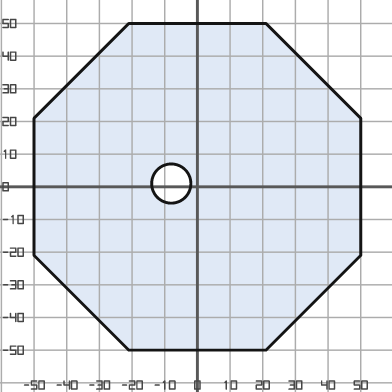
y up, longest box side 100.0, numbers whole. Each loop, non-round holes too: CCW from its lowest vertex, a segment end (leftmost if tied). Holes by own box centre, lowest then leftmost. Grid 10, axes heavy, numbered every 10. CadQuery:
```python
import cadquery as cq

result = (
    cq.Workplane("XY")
    .moveTo(-21.0, -50.0)
    .lineTo(21.0, -50.0)
    .lineTo(50.0, -21.0)
    .lineTo(50.0, 21.0)
    .lineTo(21.0, 50.0)
    .lineTo(-21.0, 50.0)
    .lineTo(-50.0, 21.0)
    .lineTo(-50.0, -21.0)
    .close()
    .moveTo(-8.0, 1.0)
    .circle(6.0)
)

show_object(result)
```